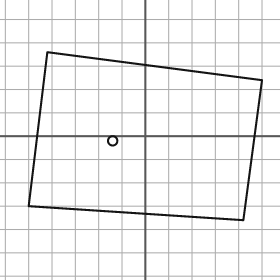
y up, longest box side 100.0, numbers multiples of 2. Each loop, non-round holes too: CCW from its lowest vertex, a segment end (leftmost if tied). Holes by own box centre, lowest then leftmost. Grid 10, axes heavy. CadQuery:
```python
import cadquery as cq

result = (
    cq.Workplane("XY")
    .moveTo(42.0, -36.0)
    .lineTo(50.0, 24.0)
    .lineTo(-42.0, 36.0)
    .lineTo(-50.0, -30.0)
    .close()
    .moveTo(-14.0, -2.0)
    .circle(2.0)
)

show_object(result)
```